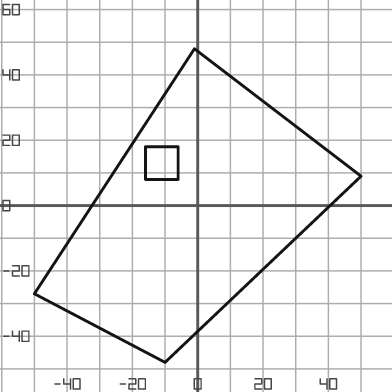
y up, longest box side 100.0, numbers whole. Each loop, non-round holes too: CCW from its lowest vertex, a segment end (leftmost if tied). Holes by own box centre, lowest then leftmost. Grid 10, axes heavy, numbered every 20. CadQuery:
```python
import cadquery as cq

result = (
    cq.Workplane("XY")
    .moveTo(-10.0, -48.0)
    .lineTo(50.0, 9.0)
    .lineTo(-1.0, 48.0)
    .lineTo(-50.0, -27.0)
    .close()
    .moveTo(-16.0, 8.0)
    .lineTo(-6.0, 8.0)
    .lineTo(-6.0, 18.0)
    .lineTo(-16.0, 18.0)
    .close()
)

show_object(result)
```